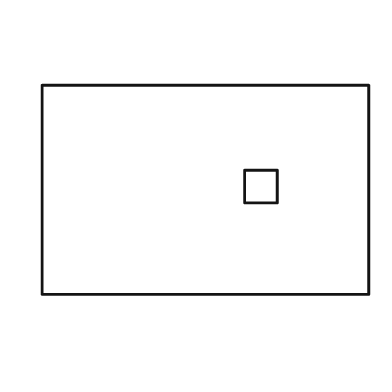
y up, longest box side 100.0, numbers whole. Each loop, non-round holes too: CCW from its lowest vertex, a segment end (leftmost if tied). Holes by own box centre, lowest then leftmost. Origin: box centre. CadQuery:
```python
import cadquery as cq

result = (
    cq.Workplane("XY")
    .moveTo(-50.0, -32.0)
    .lineTo(50.0, -32.0)
    .lineTo(50.0, 32.0)
    .lineTo(-50.0, 32.0)
    .close()
    .moveTo(12.0, -4.0)
    .lineTo(22.0, -4.0)
    .lineTo(22.0, 6.0)
    .lineTo(12.0, 6.0)
    .close()
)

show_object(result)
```